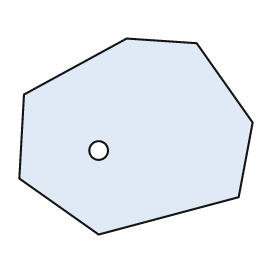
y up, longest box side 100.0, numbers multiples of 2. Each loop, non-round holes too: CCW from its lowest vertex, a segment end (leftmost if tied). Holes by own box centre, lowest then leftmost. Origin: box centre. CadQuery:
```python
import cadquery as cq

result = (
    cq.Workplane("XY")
    .moveTo(-16.0, -42.0)
    .lineTo(44.0, -26.0)
    .lineTo(50.0, 6.0)
    .lineTo(26.0, 40.0)
    .lineTo(-4.0, 42.0)
    .lineTo(-48.0, 18.0)
    .lineTo(-50.0, -18.0)
    .close()
    .moveTo(-16.0, -6.0)
    .circle(4.0)
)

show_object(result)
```